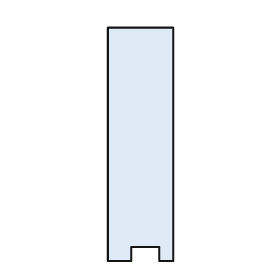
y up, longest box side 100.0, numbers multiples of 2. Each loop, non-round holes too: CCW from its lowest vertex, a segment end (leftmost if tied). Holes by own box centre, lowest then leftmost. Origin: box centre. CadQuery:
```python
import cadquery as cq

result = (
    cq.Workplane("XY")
    .moveTo(-14.0, -50.0)
    .lineTo(-4.0, -50.0)
    .lineTo(-4.0, -44.0)
    .lineTo(8.0, -44.0)
    .lineTo(8.0, -50.0)
    .lineTo(14.0, -50.0)
    .lineTo(14.0, 50.0)
    .lineTo(-14.0, 50.0)
    .close()
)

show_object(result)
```